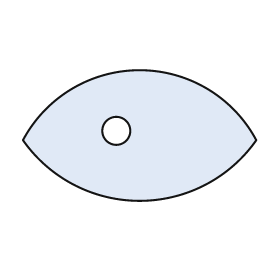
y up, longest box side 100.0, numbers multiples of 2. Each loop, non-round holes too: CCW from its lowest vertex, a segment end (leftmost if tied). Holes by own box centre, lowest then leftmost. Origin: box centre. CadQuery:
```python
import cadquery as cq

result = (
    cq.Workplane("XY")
    .moveTo(-50.0, -2.0)
    .threePointArc((0.0, -28.0), (50.0, -2.0))
    .threePointArc((0.0, 28.0), (-50.0, -2.0))
    .close()
    .moveTo(-10.0, 2.0)
    .circle(6.0)
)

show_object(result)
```